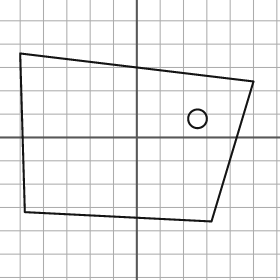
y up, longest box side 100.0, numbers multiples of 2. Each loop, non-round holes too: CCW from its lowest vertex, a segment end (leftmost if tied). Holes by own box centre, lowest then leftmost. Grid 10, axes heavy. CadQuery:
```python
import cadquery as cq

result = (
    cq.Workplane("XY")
    .moveTo(32.0, -36.0)
    .lineTo(50.0, 24.0)
    .lineTo(-50.0, 36.0)
    .lineTo(-48.0, -32.0)
    .close()
    .moveTo(26.0, 8.0)
    .circle(4.0)
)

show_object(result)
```